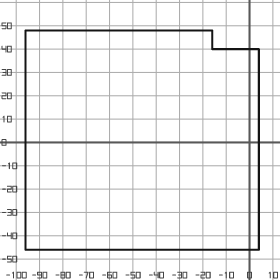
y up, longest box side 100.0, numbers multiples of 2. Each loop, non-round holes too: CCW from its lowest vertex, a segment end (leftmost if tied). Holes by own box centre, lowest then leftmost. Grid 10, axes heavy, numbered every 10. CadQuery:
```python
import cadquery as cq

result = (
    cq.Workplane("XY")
    .moveTo(-96.0, -46.0)
    .lineTo(4.0, -46.0)
    .lineTo(4.0, 40.0)
    .lineTo(-16.0, 40.0)
    .lineTo(-16.0, 48.0)
    .lineTo(-96.0, 48.0)
    .close()
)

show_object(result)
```